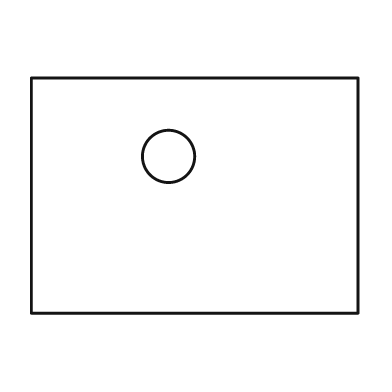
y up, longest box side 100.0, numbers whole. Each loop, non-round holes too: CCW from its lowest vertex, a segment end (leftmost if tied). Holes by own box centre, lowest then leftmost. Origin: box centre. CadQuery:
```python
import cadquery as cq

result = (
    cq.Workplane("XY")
    .moveTo(-50.0, -36.0)
    .lineTo(50.0, -36.0)
    .lineTo(50.0, 36.0)
    .lineTo(-50.0, 36.0)
    .close()
    .moveTo(-8.0, 12.0)
    .circle(8.0)
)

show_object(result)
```